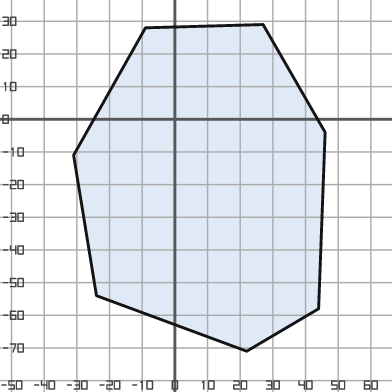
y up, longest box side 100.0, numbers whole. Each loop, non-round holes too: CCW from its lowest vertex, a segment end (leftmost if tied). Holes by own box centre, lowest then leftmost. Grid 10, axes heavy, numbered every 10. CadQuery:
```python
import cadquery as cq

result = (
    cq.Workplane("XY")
    .moveTo(22.0, -71.0)
    .lineTo(44.0, -58.0)
    .lineTo(46.0, -4.0)
    .lineTo(27.0, 29.0)
    .lineTo(-9.0, 28.0)
    .lineTo(-31.0, -11.0)
    .lineTo(-24.0, -54.0)
    .close()
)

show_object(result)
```